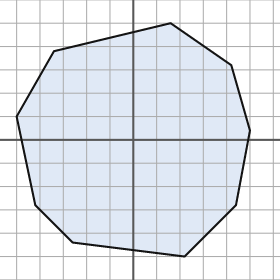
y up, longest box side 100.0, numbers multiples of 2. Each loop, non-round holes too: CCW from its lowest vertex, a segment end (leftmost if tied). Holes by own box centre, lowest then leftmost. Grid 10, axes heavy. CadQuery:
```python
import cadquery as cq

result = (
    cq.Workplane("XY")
    .moveTo(22.0, -50.0)
    .lineTo(44.0, -28.0)
    .lineTo(50.0, 4.0)
    .lineTo(42.0, 32.0)
    .lineTo(16.0, 50.0)
    .lineTo(-34.0, 38.0)
    .lineTo(-50.0, 10.0)
    .lineTo(-42.0, -28.0)
    .lineTo(-26.0, -44.0)
    .close()
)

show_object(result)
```